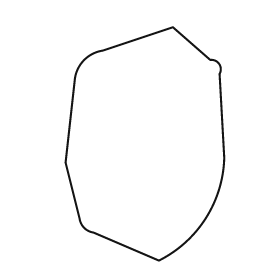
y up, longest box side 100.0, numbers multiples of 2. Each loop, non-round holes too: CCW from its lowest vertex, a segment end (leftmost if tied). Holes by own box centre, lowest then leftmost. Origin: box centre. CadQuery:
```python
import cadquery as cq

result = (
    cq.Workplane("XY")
    .moveTo(6.0, -50.0)
    .threePointArc((26.0, -32.0), (34.0, -6.0))
    .lineTo(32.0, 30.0)
    .threePointArc((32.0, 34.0), (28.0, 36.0))
    .lineTo(12.0, 50.0)
    .lineTo(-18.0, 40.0)
    .threePointArc((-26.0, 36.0), (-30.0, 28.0))
    .lineTo(-34.0, -8.0)
    .lineTo(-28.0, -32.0)
    .threePointArc((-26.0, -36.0), (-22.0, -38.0))
    .close()
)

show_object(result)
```